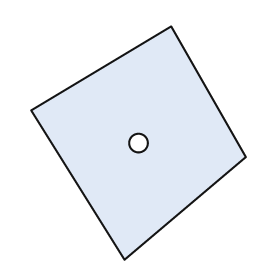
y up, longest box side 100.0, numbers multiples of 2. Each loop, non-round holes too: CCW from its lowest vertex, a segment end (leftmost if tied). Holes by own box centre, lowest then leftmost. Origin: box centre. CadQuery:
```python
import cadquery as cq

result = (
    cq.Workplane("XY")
    .moveTo(-6.0, -50.0)
    .lineTo(46.0, -6.0)
    .lineTo(14.0, 50.0)
    .lineTo(-46.0, 14.0)
    .close()
    .moveTo(0.0, 0.0)
    .circle(4.0)
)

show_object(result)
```